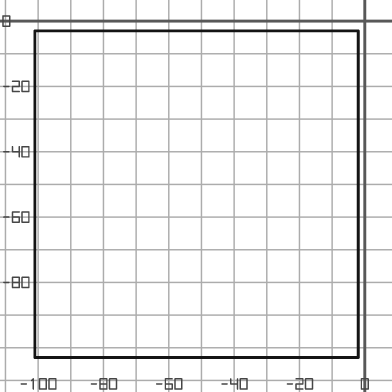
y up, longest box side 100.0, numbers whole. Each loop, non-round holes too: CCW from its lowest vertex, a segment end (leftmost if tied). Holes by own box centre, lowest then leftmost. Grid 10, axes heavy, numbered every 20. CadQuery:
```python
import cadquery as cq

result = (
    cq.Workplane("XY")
    .moveTo(-101.0, -103.0)
    .lineTo(-2.0, -103.0)
    .lineTo(-2.0, -3.0)
    .lineTo(-101.0, -3.0)
    .close()
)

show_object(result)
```